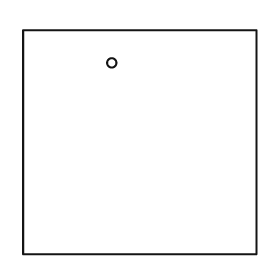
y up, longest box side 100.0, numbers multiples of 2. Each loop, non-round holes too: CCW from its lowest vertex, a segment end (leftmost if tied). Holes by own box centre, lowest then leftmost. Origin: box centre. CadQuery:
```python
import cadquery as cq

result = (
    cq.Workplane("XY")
    .moveTo(-50.0, -48.0)
    .lineTo(50.0, -48.0)
    .lineTo(50.0, 48.0)
    .lineTo(-50.0, 48.0)
    .close()
    .moveTo(-12.0, 34.0)
    .circle(2.0)
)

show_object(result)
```